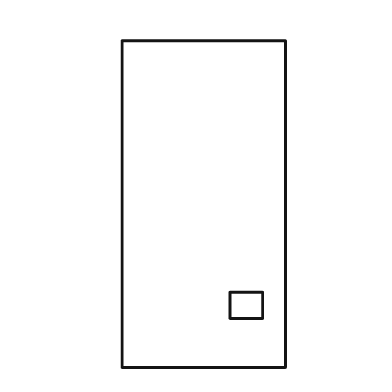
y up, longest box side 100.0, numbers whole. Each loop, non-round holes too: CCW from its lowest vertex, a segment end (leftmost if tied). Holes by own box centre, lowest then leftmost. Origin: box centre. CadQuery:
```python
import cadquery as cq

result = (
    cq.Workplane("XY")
    .moveTo(-25.0, -50.0)
    .lineTo(25.0, -50.0)
    .lineTo(25.0, 50.0)
    .lineTo(-25.0, 50.0)
    .close()
    .moveTo(8.0, -35.0)
    .lineTo(18.0, -35.0)
    .lineTo(18.0, -27.0)
    .lineTo(8.0, -27.0)
    .close()
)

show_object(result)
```